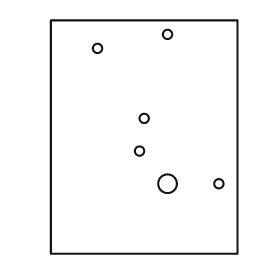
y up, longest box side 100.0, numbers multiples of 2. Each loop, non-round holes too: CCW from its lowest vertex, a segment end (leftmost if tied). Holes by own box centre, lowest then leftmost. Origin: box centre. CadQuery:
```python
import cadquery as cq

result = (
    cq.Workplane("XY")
    .moveTo(-40.0, -50.0)
    .lineTo(40.0, -50.0)
    .lineTo(40.0, 50.0)
    .lineTo(-40.0, 50.0)
    .close()
    .moveTo(10.0, -20.0)
    .circle(4.0)
    .moveTo(32.0, -20.0)
    .circle(2.0)
    .moveTo(-2.0, -6.0)
    .circle(2.0)
    .moveTo(0.0, 8.0)
    .circle(2.0)
    .moveTo(-20.0, 38.0)
    .circle(2.0)
    .moveTo(10.0, 44.0)
    .circle(2.0)
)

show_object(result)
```